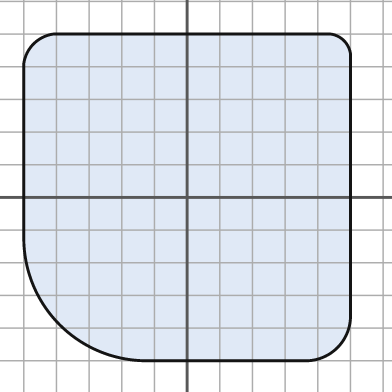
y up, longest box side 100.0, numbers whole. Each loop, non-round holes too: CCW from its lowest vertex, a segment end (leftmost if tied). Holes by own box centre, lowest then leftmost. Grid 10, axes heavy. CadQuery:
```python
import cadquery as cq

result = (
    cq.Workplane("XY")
    .moveTo(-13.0, -50.0)
    .lineTo(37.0, -50.0)
    .threePointArc((46.0, -46.0), (50.0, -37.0))
    .lineTo(50.0, 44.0)
    .threePointArc((48.0, 48.0), (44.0, 50.0))
    .lineTo(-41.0, 50.0)
    .threePointArc((-47.0, 47.0), (-50.0, 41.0))
    .lineTo(-50.0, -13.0)
    .threePointArc((-39.0, -39.0), (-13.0, -50.0))
    .close()
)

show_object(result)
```